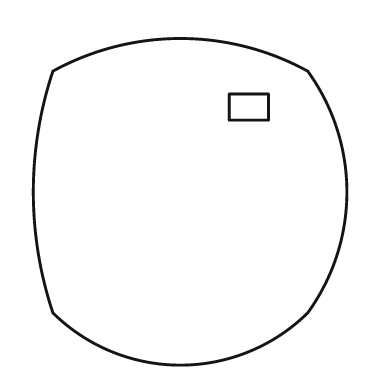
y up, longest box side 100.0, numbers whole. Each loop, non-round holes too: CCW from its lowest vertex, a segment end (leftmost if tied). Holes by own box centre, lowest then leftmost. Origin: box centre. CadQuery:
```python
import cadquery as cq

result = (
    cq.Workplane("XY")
    .moveTo(-42.0, -34.0)
    .threePointArc((-3.0, -50.0), (36.0, -34.0))
    .threePointArc((48.0, 3.0), (36.0, 40.0))
    .threePointArc((-3.0, 50.0), (-42.0, 40.0))
    .threePointArc((-48.0, 3.0), (-42.0, -34.0))
    .close()
    .moveTo(12.0, 25.0)
    .lineTo(24.0, 25.0)
    .lineTo(24.0, 33.0)
    .lineTo(12.0, 33.0)
    .close()
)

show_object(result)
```